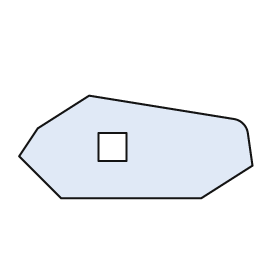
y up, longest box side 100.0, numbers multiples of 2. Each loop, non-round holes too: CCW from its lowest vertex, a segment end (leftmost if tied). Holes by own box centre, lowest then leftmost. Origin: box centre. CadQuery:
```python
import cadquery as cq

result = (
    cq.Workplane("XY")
    .moveTo(-32.0, -22.0)
    .lineTo(28.0, -22.0)
    .lineTo(50.0, -8.0)
    .lineTo(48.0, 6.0)
    .threePointArc((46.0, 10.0), (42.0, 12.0))
    .lineTo(-20.0, 22.0)
    .lineTo(-42.0, 8.0)
    .lineTo(-50.0, -4.0)
    .close()
    .moveTo(-16.0, -6.0)
    .lineTo(-4.0, -6.0)
    .lineTo(-4.0, 6.0)
    .lineTo(-16.0, 6.0)
    .close()
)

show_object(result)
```